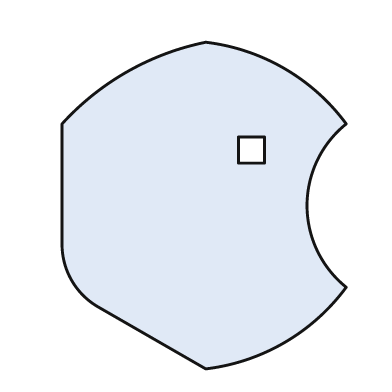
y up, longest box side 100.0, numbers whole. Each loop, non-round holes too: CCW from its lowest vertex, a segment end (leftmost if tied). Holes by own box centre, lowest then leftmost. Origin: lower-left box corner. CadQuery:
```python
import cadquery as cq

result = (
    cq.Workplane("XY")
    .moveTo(44.0, 0.0)
    .threePointArc((68.0, 8.0), (87.0, 25.0))
    .threePointArc((75.0, 50.0), (87.0, 75.0))
    .threePointArc((68.0, 92.0), (44.0, 100.0))
    .threePointArc((20.0, 91.0), (0.0, 75.0))
    .lineTo(0.0, 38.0)
    .threePointArc((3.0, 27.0), (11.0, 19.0))
    .close()
    .moveTo(54.0, 63.0)
    .lineTo(62.0, 63.0)
    .lineTo(62.0, 71.0)
    .lineTo(54.0, 71.0)
    .close()
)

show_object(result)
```